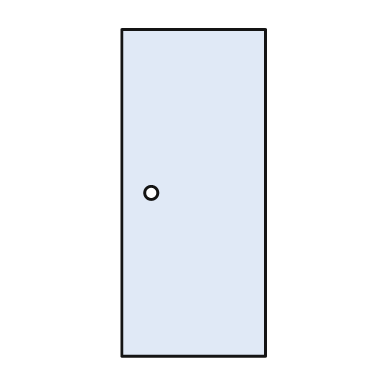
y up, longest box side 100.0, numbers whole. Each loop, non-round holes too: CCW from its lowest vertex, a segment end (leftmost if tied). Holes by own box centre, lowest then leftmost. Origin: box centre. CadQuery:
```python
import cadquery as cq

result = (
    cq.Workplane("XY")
    .moveTo(-22.0, -50.0)
    .lineTo(22.0, -50.0)
    .lineTo(22.0, 50.0)
    .lineTo(-22.0, 50.0)
    .close()
    .moveTo(-13.0, 0.0)
    .circle(2.0)
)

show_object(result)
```